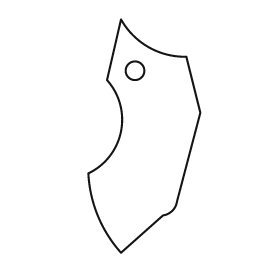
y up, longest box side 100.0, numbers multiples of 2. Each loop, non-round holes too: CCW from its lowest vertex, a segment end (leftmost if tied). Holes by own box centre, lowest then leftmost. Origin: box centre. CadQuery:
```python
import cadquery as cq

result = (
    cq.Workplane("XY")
    .moveTo(-10.0, -50.0)
    .lineTo(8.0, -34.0)
    .threePointArc((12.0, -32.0), (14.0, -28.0))
    .lineTo(24.0, 10.0)
    .lineTo(18.0, 34.0)
    .threePointArc((2.0, 38.0), (-10.0, 50.0))
    .lineTo(-16.0, 24.0)
    .threePointArc((-10.0, 2.0), (-24.0, -16.0))
    .threePointArc((-20.0, -34.0), (-10.0, -50.0))
    .close()
    .moveTo(-4.0, 28.0)
    .circle(4.0)
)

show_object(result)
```